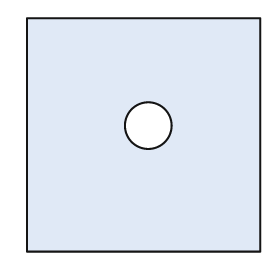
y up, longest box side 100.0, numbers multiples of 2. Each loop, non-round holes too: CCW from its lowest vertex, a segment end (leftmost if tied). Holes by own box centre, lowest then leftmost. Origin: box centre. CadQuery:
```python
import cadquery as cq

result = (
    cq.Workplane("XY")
    .moveTo(-50.0, -50.0)
    .lineTo(50.0, -50.0)
    .lineTo(50.0, 50.0)
    .lineTo(-50.0, 50.0)
    .close()
    .moveTo(2.0, 4.0)
    .circle(10.0)
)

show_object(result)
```